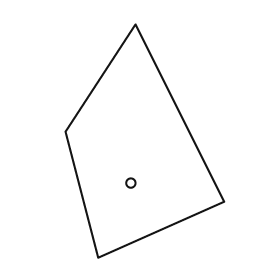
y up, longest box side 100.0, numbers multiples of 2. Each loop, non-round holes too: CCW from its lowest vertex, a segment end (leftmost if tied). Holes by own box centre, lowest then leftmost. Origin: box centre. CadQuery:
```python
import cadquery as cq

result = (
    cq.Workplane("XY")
    .moveTo(-20.0, -50.0)
    .lineTo(34.0, -26.0)
    .lineTo(-4.0, 50.0)
    .lineTo(-34.0, 4.0)
    .close()
    .moveTo(-6.0, -18.0)
    .circle(2.0)
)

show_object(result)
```